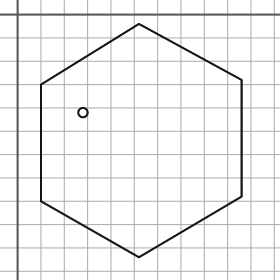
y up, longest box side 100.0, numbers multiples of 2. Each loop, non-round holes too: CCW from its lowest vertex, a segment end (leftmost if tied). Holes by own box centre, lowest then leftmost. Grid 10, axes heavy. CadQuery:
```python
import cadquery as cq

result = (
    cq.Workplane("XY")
    .moveTo(52.0, -104.0)
    .lineTo(96.0, -78.0)
    .lineTo(96.0, -28.0)
    .lineTo(52.0, -4.0)
    .lineTo(10.0, -30.0)
    .lineTo(10.0, -80.0)
    .close()
    .moveTo(28.0, -42.0)
    .circle(2.0)
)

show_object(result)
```